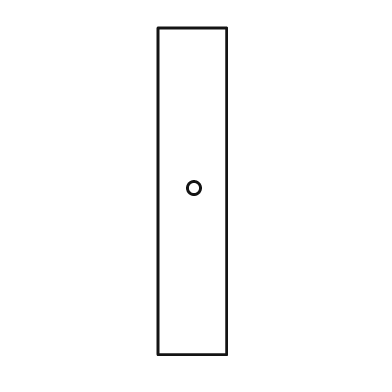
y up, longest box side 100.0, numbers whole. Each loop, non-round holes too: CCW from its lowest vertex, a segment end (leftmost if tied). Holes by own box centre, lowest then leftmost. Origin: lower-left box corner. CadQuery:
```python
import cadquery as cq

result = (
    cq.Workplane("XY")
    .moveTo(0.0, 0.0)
    .lineTo(21.0, 0.0)
    .lineTo(21.0, 100.0)
    .lineTo(0.0, 100.0)
    .close()
    .moveTo(11.0, 51.0)
    .circle(2.0)
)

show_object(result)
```